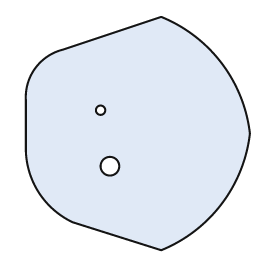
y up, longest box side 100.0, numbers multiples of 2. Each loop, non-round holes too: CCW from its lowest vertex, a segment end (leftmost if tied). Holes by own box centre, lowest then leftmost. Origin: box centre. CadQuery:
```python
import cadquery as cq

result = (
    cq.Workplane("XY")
    .moveTo(10.0, -50.0)
    .threePointArc((36.0, -30.0), (48.0, 0.0))
    .threePointArc((36.0, 30.0), (10.0, 50.0))
    .lineTo(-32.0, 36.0)
    .threePointArc((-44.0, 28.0), (-48.0, 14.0))
    .lineTo(-48.0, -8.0)
    .threePointArc((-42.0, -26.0), (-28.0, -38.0))
    .close()
    .moveTo(-12.0, -14.0)
    .circle(4.0)
    .moveTo(-16.0, 10.0)
    .circle(2.0)
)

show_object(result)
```